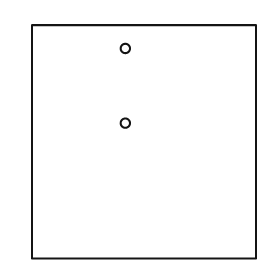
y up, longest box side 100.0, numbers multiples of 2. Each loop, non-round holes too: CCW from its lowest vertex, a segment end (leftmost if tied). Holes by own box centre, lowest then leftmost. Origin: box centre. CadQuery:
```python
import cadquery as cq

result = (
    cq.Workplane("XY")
    .moveTo(-48.0, -50.0)
    .lineTo(48.0, -50.0)
    .lineTo(48.0, 50.0)
    .lineTo(-48.0, 50.0)
    .close()
    .moveTo(-8.0, 8.0)
    .circle(2.0)
    .moveTo(-8.0, 40.0)
    .circle(2.0)
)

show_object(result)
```